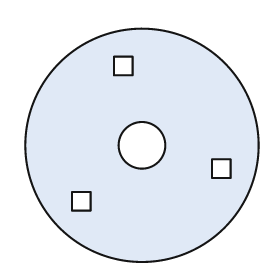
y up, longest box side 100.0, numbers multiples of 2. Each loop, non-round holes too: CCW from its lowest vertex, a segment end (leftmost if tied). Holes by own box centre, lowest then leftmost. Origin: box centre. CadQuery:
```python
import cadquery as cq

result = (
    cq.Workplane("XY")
    .moveTo(0.0, 0.0)
    .circle(50.0)
    .moveTo(-30.0, -28.0)
    .lineTo(-22.0, -28.0)
    .lineTo(-22.0, -20.0)
    .lineTo(-30.0, -20.0)
    .close()
    .moveTo(30.0, -14.0)
    .lineTo(38.0, -14.0)
    .lineTo(38.0, -6.0)
    .lineTo(30.0, -6.0)
    .close()
    .moveTo(0.0, 0.0)
    .circle(10.0)
    .moveTo(-12.0, 30.0)
    .lineTo(-4.0, 30.0)
    .lineTo(-4.0, 38.0)
    .lineTo(-12.0, 38.0)
    .close()
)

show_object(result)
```